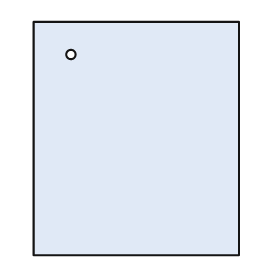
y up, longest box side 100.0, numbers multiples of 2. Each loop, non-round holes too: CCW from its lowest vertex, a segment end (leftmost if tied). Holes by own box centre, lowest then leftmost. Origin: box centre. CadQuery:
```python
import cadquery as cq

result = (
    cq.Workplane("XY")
    .moveTo(-44.0, -50.0)
    .lineTo(44.0, -50.0)
    .lineTo(44.0, 50.0)
    .lineTo(-44.0, 50.0)
    .close()
    .moveTo(-28.0, 36.0)
    .circle(2.0)
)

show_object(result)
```